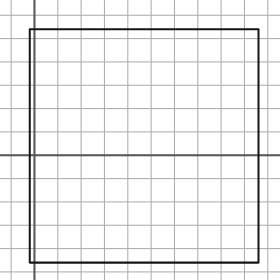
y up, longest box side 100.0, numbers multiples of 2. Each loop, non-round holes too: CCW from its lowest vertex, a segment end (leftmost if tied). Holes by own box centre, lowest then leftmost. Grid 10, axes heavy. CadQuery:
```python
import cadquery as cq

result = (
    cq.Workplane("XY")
    .moveTo(-2.0, -46.0)
    .lineTo(96.0, -46.0)
    .lineTo(96.0, 54.0)
    .lineTo(-2.0, 54.0)
    .close()
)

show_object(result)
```